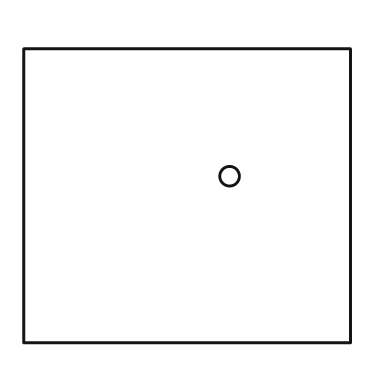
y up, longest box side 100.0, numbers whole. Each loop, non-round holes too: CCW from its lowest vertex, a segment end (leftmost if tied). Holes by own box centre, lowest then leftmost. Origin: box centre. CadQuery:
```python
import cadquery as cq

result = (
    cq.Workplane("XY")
    .moveTo(-50.0, -45.0)
    .lineTo(50.0, -45.0)
    .lineTo(50.0, 45.0)
    .lineTo(-50.0, 45.0)
    .close()
    .moveTo(13.0, 6.0)
    .circle(3.0)
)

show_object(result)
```